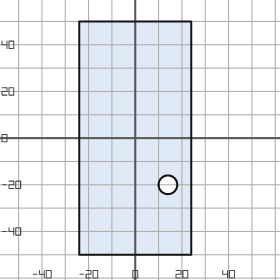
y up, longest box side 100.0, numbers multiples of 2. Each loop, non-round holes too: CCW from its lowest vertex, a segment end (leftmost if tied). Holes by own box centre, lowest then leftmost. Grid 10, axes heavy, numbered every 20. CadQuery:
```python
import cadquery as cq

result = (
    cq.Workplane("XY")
    .moveTo(-24.0, -50.0)
    .lineTo(24.0, -50.0)
    .lineTo(24.0, 50.0)
    .lineTo(-24.0, 50.0)
    .close()
    .moveTo(14.0, -20.0)
    .circle(4.0)
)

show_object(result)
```